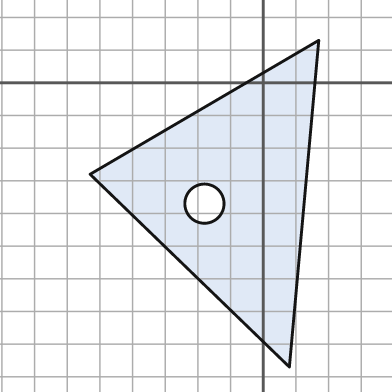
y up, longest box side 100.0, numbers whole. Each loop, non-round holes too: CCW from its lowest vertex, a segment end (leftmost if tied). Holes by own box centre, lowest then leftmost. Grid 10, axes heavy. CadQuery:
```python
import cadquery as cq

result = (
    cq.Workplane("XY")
    .moveTo(8.0, -87.0)
    .lineTo(17.0, 13.0)
    .lineTo(-53.0, -28.0)
    .close()
    .moveTo(-18.0, -37.0)
    .circle(6.0)
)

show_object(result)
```